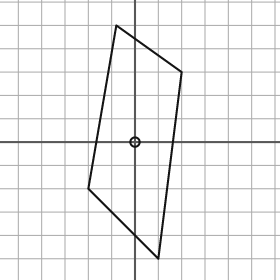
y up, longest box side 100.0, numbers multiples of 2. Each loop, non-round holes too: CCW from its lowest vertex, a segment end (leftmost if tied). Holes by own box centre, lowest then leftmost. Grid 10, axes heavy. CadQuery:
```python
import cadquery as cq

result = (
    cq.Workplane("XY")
    .moveTo(10.0, -50.0)
    .lineTo(20.0, 30.0)
    .lineTo(-8.0, 50.0)
    .lineTo(-20.0, -20.0)
    .close()
    .moveTo(0.0, 0.0)
    .circle(2.0)
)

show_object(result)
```